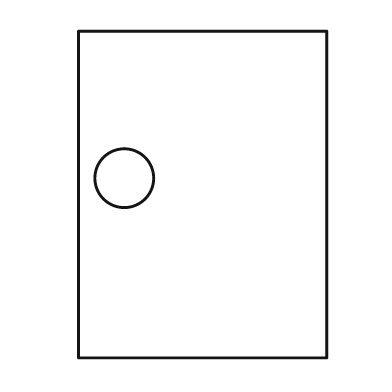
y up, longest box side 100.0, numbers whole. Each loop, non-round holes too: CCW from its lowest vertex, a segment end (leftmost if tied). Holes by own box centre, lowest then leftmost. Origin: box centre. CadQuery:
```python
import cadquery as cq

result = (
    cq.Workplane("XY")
    .moveTo(-38.0, -50.0)
    .lineTo(38.0, -50.0)
    .lineTo(38.0, 50.0)
    .lineTo(-38.0, 50.0)
    .close()
    .moveTo(-24.0, 5.0)
    .circle(9.0)
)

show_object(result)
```